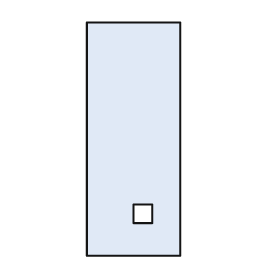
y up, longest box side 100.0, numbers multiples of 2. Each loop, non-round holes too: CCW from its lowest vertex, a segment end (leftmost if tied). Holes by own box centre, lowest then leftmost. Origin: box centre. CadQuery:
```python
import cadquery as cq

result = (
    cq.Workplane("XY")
    .moveTo(-20.0, -50.0)
    .lineTo(20.0, -50.0)
    .lineTo(20.0, 50.0)
    .lineTo(-20.0, 50.0)
    .close()
    .moveTo(0.0, -36.0)
    .lineTo(8.0, -36.0)
    .lineTo(8.0, -28.0)
    .lineTo(0.0, -28.0)
    .close()
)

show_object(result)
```